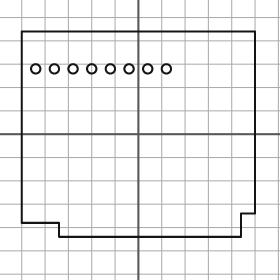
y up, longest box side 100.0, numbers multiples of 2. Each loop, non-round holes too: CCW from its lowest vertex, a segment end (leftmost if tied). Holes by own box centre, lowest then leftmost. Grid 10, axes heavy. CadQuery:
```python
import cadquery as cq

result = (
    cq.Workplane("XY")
    .moveTo(-34.0, -44.0)
    .lineTo(44.0, -44.0)
    .lineTo(44.0, -34.0)
    .lineTo(50.0, -34.0)
    .lineTo(50.0, 44.0)
    .lineTo(-50.0, 44.0)
    .lineTo(-50.0, -38.0)
    .lineTo(-34.0, -38.0)
    .close()
    .moveTo(-44.0, 28.0)
    .circle(2.0)
    .moveTo(-36.0, 28.0)
    .circle(2.0)
    .moveTo(-28.0, 28.0)
    .circle(2.0)
    .moveTo(-20.0, 28.0)
    .circle(2.0)
    .moveTo(-12.0, 28.0)
    .circle(2.0)
    .moveTo(-4.0, 28.0)
    .circle(2.0)
    .moveTo(4.0, 28.0)
    .circle(2.0)
    .moveTo(12.0, 28.0)
    .circle(2.0)
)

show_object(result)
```